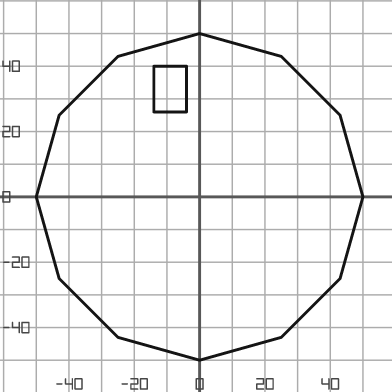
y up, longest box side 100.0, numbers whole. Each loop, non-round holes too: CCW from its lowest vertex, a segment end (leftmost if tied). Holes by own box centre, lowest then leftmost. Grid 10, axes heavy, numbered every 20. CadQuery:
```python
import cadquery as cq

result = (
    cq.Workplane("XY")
    .moveTo(0.0, -50.0)
    .lineTo(25.0, -43.0)
    .lineTo(43.0, -25.0)
    .lineTo(50.0, 0.0)
    .lineTo(43.0, 25.0)
    .lineTo(25.0, 43.0)
    .lineTo(0.0, 50.0)
    .lineTo(-25.0, 43.0)
    .lineTo(-43.0, 25.0)
    .lineTo(-50.0, 0.0)
    .lineTo(-43.0, -25.0)
    .lineTo(-25.0, -43.0)
    .close()
    .moveTo(-14.0, 26.0)
    .lineTo(-4.0, 26.0)
    .lineTo(-4.0, 40.0)
    .lineTo(-14.0, 40.0)
    .close()
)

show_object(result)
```